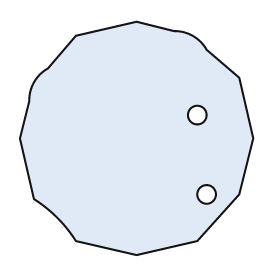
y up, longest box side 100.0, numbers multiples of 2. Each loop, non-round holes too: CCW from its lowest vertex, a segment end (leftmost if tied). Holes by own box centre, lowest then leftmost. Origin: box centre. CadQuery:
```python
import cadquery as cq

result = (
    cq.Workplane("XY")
    .moveTo(0.0, -50.0)
    .lineTo(26.0, -44.0)
    .lineTo(44.0, -24.0)
    .lineTo(50.0, 0.0)
    .lineTo(44.0, 26.0)
    .lineTo(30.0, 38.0)
    .threePointArc((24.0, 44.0), (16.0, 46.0))
    .lineTo(0.0, 50.0)
    .lineTo(-26.0, 44.0)
    .lineTo(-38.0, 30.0)
    .threePointArc((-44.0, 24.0), (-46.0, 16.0))
    .lineTo(-50.0, 0.0)
    .lineTo(-44.0, -26.0)
    .threePointArc((-34.0, -34.0), (-26.0, -44.0))
    .close()
    .moveTo(30.0, -24.0)
    .circle(4.0)
    .moveTo(26.0, 10.0)
    .circle(4.0)
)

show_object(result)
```